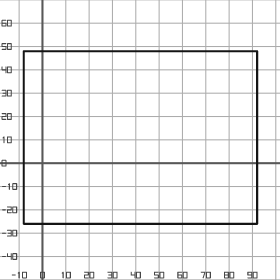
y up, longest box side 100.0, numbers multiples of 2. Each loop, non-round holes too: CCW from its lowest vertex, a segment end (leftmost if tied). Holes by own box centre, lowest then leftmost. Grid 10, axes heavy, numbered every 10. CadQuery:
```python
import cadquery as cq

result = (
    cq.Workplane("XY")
    .moveTo(-8.0, -26.0)
    .lineTo(92.0, -26.0)
    .lineTo(92.0, 48.0)
    .lineTo(-8.0, 48.0)
    .close()
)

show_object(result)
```